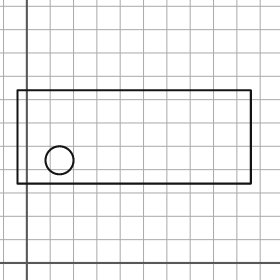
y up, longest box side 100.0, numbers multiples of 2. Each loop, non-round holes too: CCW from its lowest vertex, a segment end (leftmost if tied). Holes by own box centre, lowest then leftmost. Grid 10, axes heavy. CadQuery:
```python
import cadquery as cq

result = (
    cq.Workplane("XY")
    .moveTo(-4.0, 34.0)
    .lineTo(96.0, 34.0)
    .lineTo(96.0, 74.0)
    .lineTo(-4.0, 74.0)
    .close()
    .moveTo(14.0, 44.0)
    .circle(6.0)
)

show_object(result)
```